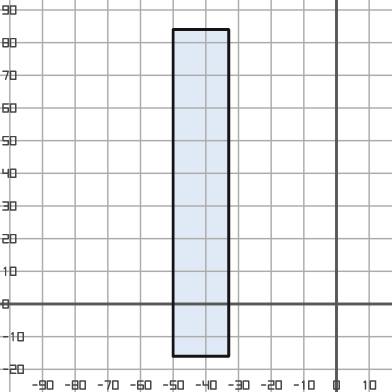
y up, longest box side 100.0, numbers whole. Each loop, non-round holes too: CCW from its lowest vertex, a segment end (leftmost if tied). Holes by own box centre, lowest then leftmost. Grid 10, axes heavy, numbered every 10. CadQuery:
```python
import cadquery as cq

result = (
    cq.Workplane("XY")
    .moveTo(-50.0, -16.0)
    .lineTo(-33.0, -16.0)
    .lineTo(-33.0, 84.0)
    .lineTo(-50.0, 84.0)
    .close()
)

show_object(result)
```